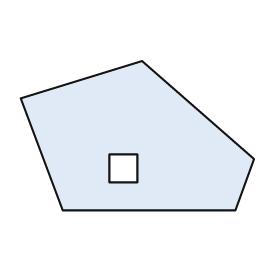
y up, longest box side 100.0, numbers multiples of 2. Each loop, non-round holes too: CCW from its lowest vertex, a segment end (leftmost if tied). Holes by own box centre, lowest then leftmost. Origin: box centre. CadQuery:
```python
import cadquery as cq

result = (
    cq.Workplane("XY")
    .moveTo(-32.0, -32.0)
    .lineTo(42.0, -32.0)
    .lineTo(50.0, -10.0)
    .lineTo(2.0, 32.0)
    .lineTo(-50.0, 16.0)
    .close()
    .moveTo(-12.0, -20.0)
    .lineTo(0.0, -20.0)
    .lineTo(0.0, -8.0)
    .lineTo(-12.0, -8.0)
    .close()
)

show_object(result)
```